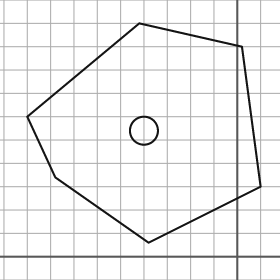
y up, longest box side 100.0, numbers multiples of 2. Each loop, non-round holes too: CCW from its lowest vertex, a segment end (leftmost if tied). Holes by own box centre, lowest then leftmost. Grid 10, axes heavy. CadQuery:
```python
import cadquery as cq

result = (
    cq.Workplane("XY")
    .moveTo(-38.0, 6.0)
    .lineTo(10.0, 30.0)
    .lineTo(2.0, 90.0)
    .lineTo(-42.0, 100.0)
    .lineTo(-90.0, 60.0)
    .lineTo(-78.0, 34.0)
    .close()
    .moveTo(-40.0, 54.0)
    .circle(6.0)
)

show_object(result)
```